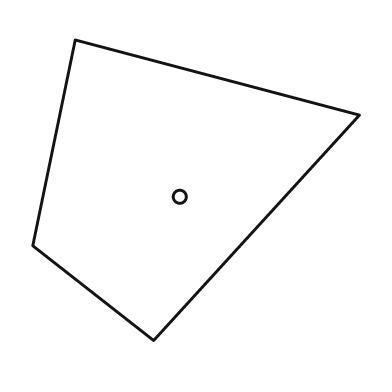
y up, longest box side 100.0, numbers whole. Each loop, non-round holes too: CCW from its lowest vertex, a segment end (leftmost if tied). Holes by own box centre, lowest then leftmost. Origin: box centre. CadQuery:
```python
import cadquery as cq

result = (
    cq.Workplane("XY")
    .moveTo(-13.0, -46.0)
    .lineTo(50.0, 23.0)
    .lineTo(-37.0, 46.0)
    .lineTo(-50.0, -17.0)
    .close()
    .moveTo(-5.0, -2.0)
    .circle(2.0)
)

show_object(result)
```